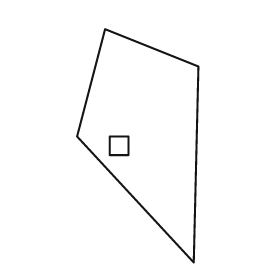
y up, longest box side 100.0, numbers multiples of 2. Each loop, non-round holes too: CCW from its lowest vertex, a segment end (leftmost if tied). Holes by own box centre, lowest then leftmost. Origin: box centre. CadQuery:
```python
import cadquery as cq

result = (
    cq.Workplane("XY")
    .moveTo(24.0, -50.0)
    .lineTo(26.0, 34.0)
    .lineTo(-14.0, 50.0)
    .lineTo(-26.0, 4.0)
    .close()
    .moveTo(-12.0, -4.0)
    .lineTo(-4.0, -4.0)
    .lineTo(-4.0, 4.0)
    .lineTo(-12.0, 4.0)
    .close()
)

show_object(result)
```